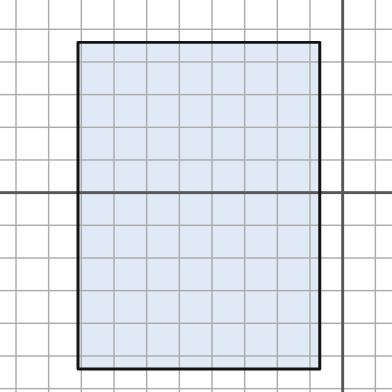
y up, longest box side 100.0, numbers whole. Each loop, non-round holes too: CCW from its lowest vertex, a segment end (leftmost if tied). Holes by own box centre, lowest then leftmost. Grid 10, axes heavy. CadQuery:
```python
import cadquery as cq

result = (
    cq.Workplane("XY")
    .moveTo(-81.0, -54.0)
    .lineTo(-7.0, -54.0)
    .lineTo(-7.0, 46.0)
    .lineTo(-81.0, 46.0)
    .close()
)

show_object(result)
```